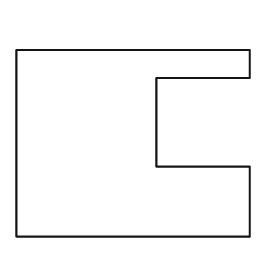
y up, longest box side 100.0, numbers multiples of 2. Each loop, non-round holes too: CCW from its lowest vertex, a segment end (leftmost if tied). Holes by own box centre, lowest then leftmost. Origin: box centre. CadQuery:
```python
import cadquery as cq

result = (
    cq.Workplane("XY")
    .moveTo(-50.0, -40.0)
    .lineTo(50.0, -40.0)
    .lineTo(50.0, -10.0)
    .lineTo(10.0, -10.0)
    .lineTo(10.0, 28.0)
    .lineTo(50.0, 28.0)
    .lineTo(50.0, 40.0)
    .lineTo(-50.0, 40.0)
    .close()
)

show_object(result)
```